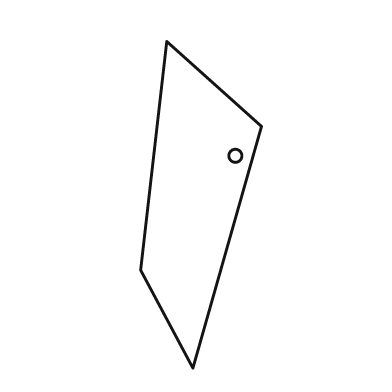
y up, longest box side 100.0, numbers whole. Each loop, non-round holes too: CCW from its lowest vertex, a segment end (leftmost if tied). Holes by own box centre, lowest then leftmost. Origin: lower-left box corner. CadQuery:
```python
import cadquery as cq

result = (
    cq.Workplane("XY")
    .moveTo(16.0, 0.0)
    .lineTo(37.0, 74.0)
    .lineTo(8.0, 100.0)
    .lineTo(0.0, 30.0)
    .close()
    .moveTo(29.0, 65.0)
    .circle(2.0)
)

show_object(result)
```